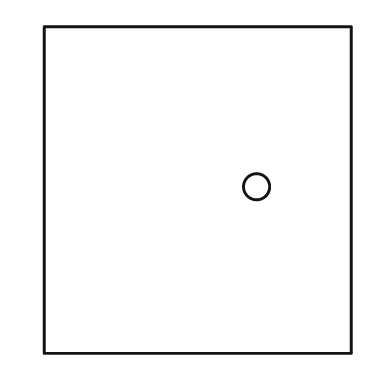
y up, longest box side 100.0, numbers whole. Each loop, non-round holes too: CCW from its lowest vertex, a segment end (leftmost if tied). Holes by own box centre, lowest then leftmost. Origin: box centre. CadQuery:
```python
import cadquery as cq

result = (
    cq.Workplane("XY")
    .moveTo(-47.0, -50.0)
    .lineTo(47.0, -50.0)
    .lineTo(47.0, 50.0)
    .lineTo(-47.0, 50.0)
    .close()
    .moveTo(18.0, 1.0)
    .circle(4.0)
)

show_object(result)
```